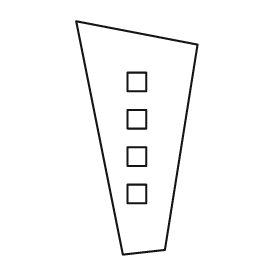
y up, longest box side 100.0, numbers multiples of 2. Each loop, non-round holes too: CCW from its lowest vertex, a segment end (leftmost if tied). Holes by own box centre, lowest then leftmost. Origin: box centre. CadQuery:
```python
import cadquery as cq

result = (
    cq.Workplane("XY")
    .moveTo(-6.0, -50.0)
    .lineTo(12.0, -48.0)
    .lineTo(26.0, 40.0)
    .lineTo(-26.0, 50.0)
    .close()
    .moveTo(-4.0, -28.0)
    .lineTo(4.0, -28.0)
    .lineTo(4.0, -20.0)
    .lineTo(-4.0, -20.0)
    .close()
    .moveTo(-4.0, -12.0)
    .lineTo(4.0, -12.0)
    .lineTo(4.0, -4.0)
    .lineTo(-4.0, -4.0)
    .close()
    .moveTo(-4.0, 4.0)
    .lineTo(4.0, 4.0)
    .lineTo(4.0, 12.0)
    .lineTo(-4.0, 12.0)
    .close()
    .moveTo(-4.0, 20.0)
    .lineTo(4.0, 20.0)
    .lineTo(4.0, 28.0)
    .lineTo(-4.0, 28.0)
    .close()
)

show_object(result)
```